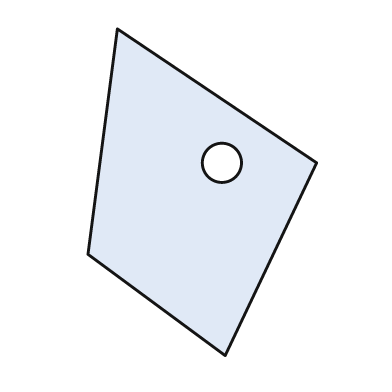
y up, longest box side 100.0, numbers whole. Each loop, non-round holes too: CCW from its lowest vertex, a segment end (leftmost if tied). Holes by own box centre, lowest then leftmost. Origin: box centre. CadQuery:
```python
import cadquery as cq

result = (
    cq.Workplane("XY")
    .moveTo(7.0, -50.0)
    .lineTo(35.0, 9.0)
    .lineTo(-26.0, 50.0)
    .lineTo(-35.0, -19.0)
    .close()
    .moveTo(6.0, 9.0)
    .circle(6.0)
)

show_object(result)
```